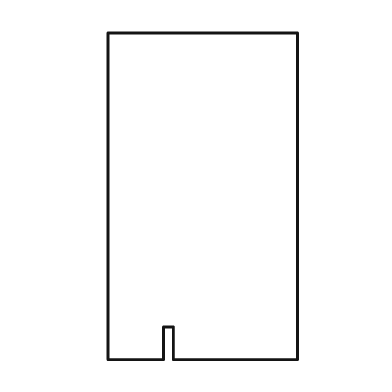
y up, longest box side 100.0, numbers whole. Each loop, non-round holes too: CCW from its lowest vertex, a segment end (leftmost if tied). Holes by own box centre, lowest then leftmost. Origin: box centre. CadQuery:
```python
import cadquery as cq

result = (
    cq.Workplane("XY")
    .moveTo(-29.0, -50.0)
    .lineTo(-12.0, -50.0)
    .lineTo(-12.0, -40.0)
    .lineTo(-9.0, -40.0)
    .lineTo(-9.0, -50.0)
    .lineTo(29.0, -50.0)
    .lineTo(29.0, 50.0)
    .lineTo(-29.0, 50.0)
    .close()
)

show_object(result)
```